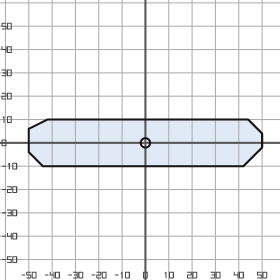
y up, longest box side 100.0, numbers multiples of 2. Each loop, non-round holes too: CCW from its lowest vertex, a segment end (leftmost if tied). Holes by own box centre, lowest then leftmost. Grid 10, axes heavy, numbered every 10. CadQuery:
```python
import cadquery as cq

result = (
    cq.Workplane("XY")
    .moveTo(-44.0, -10.0)
    .lineTo(42.0, -10.0)
    .lineTo(50.0, -2.0)
    .lineTo(50.0, 4.0)
    .lineTo(44.0, 10.0)
    .lineTo(-42.0, 10.0)
    .lineTo(-50.0, 6.0)
    .lineTo(-50.0, -4.0)
    .close()
    .moveTo(0.0, 0.0)
    .circle(2.0)
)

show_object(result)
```